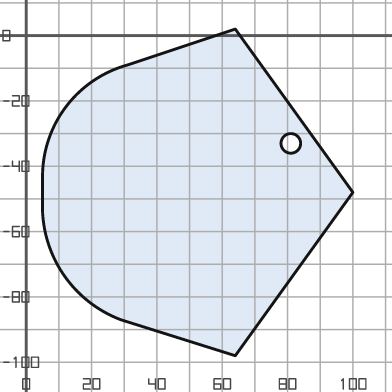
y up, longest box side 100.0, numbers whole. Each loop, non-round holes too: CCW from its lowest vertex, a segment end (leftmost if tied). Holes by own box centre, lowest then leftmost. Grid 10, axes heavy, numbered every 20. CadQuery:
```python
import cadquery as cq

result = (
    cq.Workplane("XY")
    .moveTo(64.0, -98.0)
    .lineTo(100.0, -48.0)
    .lineTo(64.0, 2.0)
    .lineTo(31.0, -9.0)
    .threePointArc((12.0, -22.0), (5.0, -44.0))
    .lineTo(5.0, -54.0)
    .threePointArc((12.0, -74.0), (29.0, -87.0))
    .close()
    .moveTo(81.0, -33.0)
    .circle(3.0)
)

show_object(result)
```